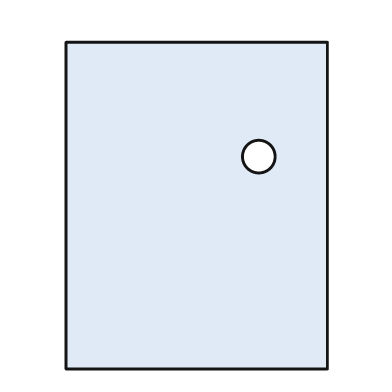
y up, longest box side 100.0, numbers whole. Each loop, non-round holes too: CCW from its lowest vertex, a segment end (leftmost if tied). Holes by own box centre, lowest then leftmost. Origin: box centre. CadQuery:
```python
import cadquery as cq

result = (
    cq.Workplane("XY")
    .moveTo(-40.0, -50.0)
    .lineTo(40.0, -50.0)
    .lineTo(40.0, 50.0)
    .lineTo(-40.0, 50.0)
    .close()
    .moveTo(19.0, 15.0)
    .circle(5.0)
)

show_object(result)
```